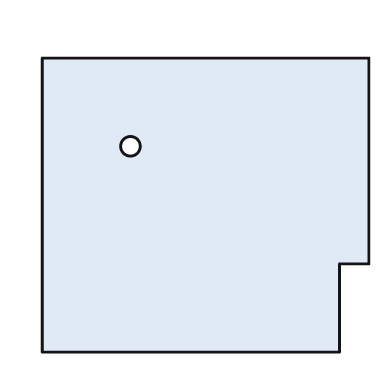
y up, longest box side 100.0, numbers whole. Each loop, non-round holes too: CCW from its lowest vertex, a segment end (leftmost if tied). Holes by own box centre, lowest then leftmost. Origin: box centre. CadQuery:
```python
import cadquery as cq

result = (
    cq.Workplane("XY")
    .moveTo(-50.0, -45.0)
    .lineTo(41.0, -45.0)
    .lineTo(41.0, -18.0)
    .lineTo(50.0, -18.0)
    .lineTo(50.0, 45.0)
    .lineTo(-50.0, 45.0)
    .close()
    .moveTo(-23.0, 18.0)
    .circle(3.0)
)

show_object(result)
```